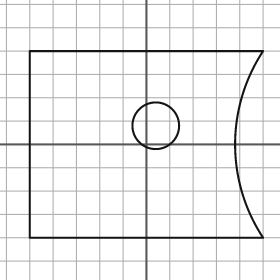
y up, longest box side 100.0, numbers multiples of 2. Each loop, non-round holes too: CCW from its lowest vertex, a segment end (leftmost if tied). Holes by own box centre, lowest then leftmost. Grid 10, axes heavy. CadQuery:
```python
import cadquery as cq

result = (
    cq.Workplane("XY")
    .moveTo(-50.0, -40.0)
    .lineTo(50.0, -40.0)
    .threePointArc((38.0, 0.0), (50.0, 40.0))
    .lineTo(-50.0, 40.0)
    .close()
    .moveTo(4.0, 8.0)
    .circle(10.0)
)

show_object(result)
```